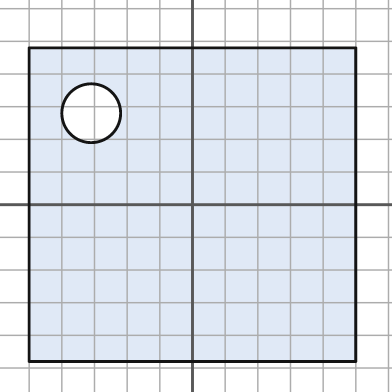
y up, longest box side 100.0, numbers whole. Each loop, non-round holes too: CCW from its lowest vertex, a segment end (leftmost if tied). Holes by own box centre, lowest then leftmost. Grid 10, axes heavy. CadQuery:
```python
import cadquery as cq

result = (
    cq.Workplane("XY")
    .moveTo(-50.0, -48.0)
    .lineTo(50.0, -48.0)
    .lineTo(50.0, 48.0)
    .lineTo(-50.0, 48.0)
    .close()
    .moveTo(-31.0, 28.0)
    .circle(9.0)
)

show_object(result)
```